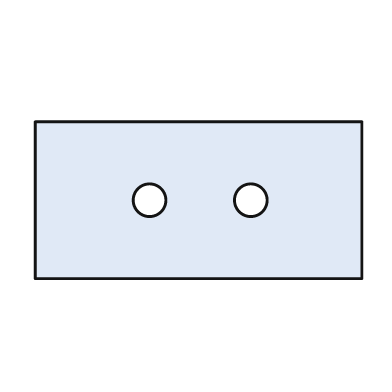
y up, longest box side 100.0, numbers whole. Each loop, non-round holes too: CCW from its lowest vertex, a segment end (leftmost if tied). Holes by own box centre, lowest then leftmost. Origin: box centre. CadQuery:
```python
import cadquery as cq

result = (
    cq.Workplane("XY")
    .moveTo(-50.0, -24.0)
    .lineTo(50.0, -24.0)
    .lineTo(50.0, 24.0)
    .lineTo(-50.0, 24.0)
    .close()
    .moveTo(-15.0, 0.0)
    .circle(5.0)
    .moveTo(16.0, 0.0)
    .circle(5.0)
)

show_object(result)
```